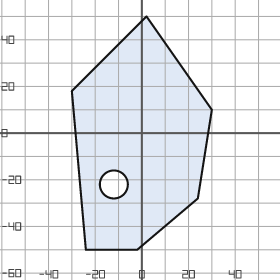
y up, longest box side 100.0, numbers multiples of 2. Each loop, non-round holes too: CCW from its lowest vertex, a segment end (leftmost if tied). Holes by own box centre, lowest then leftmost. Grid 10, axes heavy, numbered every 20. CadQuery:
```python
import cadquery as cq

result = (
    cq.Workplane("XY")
    .moveTo(-24.0, -50.0)
    .lineTo(-2.0, -50.0)
    .lineTo(24.0, -28.0)
    .lineTo(30.0, 10.0)
    .lineTo(2.0, 50.0)
    .lineTo(-30.0, 18.0)
    .close()
    .moveTo(-12.0, -22.0)
    .circle(6.0)
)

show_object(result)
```